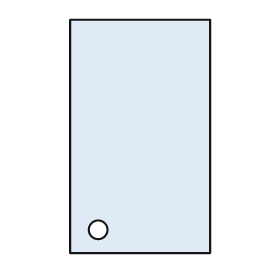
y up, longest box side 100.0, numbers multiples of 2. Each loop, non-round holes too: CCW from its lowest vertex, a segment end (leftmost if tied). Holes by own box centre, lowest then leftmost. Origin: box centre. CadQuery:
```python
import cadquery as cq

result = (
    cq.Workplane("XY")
    .moveTo(-30.0, -50.0)
    .lineTo(30.0, -50.0)
    .lineTo(30.0, 50.0)
    .lineTo(-30.0, 50.0)
    .close()
    .moveTo(-18.0, -40.0)
    .circle(4.0)
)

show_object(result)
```